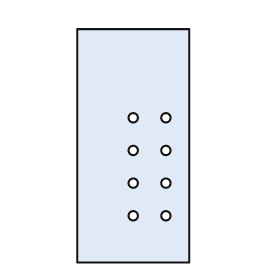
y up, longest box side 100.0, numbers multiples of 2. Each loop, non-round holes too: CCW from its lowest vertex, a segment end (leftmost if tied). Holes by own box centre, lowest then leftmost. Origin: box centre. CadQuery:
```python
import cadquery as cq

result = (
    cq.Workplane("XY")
    .moveTo(-24.0, -50.0)
    .lineTo(24.0, -50.0)
    .lineTo(24.0, 50.0)
    .lineTo(-24.0, 50.0)
    .close()
    .moveTo(0.0, -30.0)
    .circle(2.0)
    .moveTo(14.0, -30.0)
    .circle(2.0)
    .moveTo(0.0, -16.0)
    .circle(2.0)
    .moveTo(14.0, -16.0)
    .circle(2.0)
    .moveTo(0.0, -2.0)
    .circle(2.0)
    .moveTo(14.0, -2.0)
    .circle(2.0)
    .moveTo(0.0, 12.0)
    .circle(2.0)
    .moveTo(14.0, 12.0)
    .circle(2.0)
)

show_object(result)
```